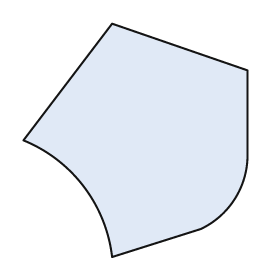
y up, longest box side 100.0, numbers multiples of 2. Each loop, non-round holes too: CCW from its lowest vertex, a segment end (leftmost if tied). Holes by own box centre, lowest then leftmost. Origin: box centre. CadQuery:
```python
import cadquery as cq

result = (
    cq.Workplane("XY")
    .moveTo(-10.0, -50.0)
    .lineTo(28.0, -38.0)
    .threePointArc((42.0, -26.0), (48.0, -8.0))
    .lineTo(48.0, 30.0)
    .lineTo(-10.0, 50.0)
    .lineTo(-48.0, 0.0)
    .threePointArc((-22.0, -20.0), (-10.0, -50.0))
    .close()
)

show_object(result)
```